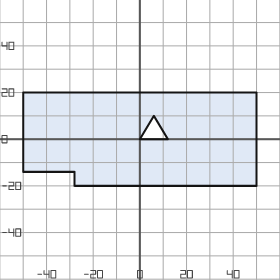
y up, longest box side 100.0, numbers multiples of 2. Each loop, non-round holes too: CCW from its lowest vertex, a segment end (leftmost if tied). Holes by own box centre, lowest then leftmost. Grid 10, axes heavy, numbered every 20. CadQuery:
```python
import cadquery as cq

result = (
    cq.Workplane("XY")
    .moveTo(-28.0, -20.0)
    .lineTo(50.0, -20.0)
    .lineTo(50.0, 20.0)
    .lineTo(-50.0, 20.0)
    .lineTo(-50.0, -14.0)
    .lineTo(-28.0, -14.0)
    .close()
    .moveTo(0.0, 0.0)
    .lineTo(12.0, 0.0)
    .lineTo(6.0, 10.0)
    .close()
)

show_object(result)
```